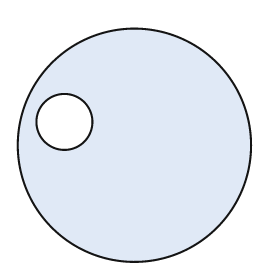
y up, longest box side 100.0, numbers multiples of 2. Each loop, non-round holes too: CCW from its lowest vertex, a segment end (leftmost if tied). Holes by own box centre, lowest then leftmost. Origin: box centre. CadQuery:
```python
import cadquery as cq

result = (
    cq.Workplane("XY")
    .moveTo(0.0, 0.0)
    .circle(50.0)
    .moveTo(-30.0, 10.0)
    .circle(12.0)
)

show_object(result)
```